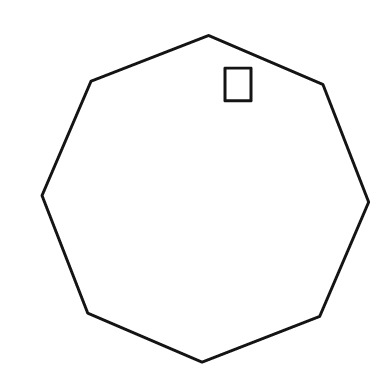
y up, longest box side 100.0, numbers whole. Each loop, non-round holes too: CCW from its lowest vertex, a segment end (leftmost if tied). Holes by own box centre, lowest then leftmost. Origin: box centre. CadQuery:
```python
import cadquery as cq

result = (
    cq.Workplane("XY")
    .moveTo(-1.0, -50.0)
    .lineTo(35.0, -36.0)
    .lineTo(50.0, -1.0)
    .lineTo(36.0, 35.0)
    .lineTo(1.0, 50.0)
    .lineTo(-35.0, 36.0)
    .lineTo(-50.0, 1.0)
    .lineTo(-36.0, -35.0)
    .close()
    .moveTo(6.0, 30.0)
    .lineTo(14.0, 30.0)
    .lineTo(14.0, 40.0)
    .lineTo(6.0, 40.0)
    .close()
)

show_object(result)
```